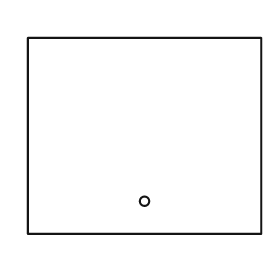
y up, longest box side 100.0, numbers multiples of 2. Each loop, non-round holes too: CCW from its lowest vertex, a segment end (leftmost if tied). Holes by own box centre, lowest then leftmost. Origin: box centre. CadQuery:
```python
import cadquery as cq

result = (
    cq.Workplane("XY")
    .moveTo(-50.0, -42.0)
    .lineTo(50.0, -42.0)
    .lineTo(50.0, 42.0)
    .lineTo(-50.0, 42.0)
    .close()
    .moveTo(0.0, -28.0)
    .circle(2.0)
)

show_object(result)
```